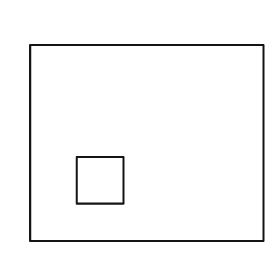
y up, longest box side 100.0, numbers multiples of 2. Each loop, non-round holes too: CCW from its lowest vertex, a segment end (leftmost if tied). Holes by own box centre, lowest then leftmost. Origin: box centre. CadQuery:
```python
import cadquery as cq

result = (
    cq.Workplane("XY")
    .moveTo(-50.0, -42.0)
    .lineTo(50.0, -42.0)
    .lineTo(50.0, 42.0)
    .lineTo(-50.0, 42.0)
    .close()
    .moveTo(-30.0, -26.0)
    .lineTo(-10.0, -26.0)
    .lineTo(-10.0, -6.0)
    .lineTo(-30.0, -6.0)
    .close()
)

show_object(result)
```